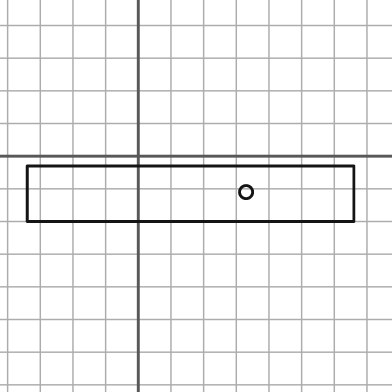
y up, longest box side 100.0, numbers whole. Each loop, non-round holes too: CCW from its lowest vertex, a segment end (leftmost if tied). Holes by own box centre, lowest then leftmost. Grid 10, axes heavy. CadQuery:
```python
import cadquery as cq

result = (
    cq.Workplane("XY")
    .moveTo(-34.0, -20.0)
    .lineTo(66.0, -20.0)
    .lineTo(66.0, -3.0)
    .lineTo(-34.0, -3.0)
    .close()
    .moveTo(33.0, -11.0)
    .circle(2.0)
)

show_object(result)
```